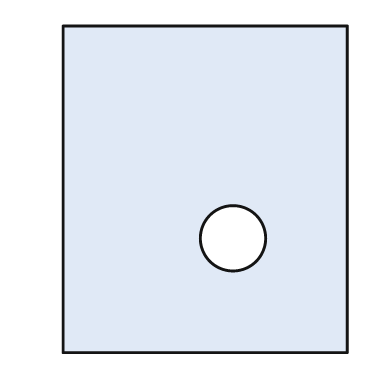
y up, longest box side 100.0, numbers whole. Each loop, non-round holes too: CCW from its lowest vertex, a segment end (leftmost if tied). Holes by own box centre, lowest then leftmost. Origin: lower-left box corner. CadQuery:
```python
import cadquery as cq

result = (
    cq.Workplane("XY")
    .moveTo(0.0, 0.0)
    .lineTo(87.0, 0.0)
    .lineTo(87.0, 100.0)
    .lineTo(0.0, 100.0)
    .close()
    .moveTo(52.0, 35.0)
    .circle(10.0)
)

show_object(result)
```